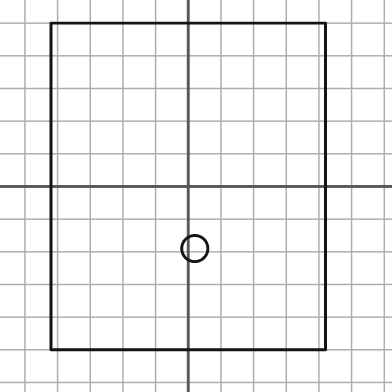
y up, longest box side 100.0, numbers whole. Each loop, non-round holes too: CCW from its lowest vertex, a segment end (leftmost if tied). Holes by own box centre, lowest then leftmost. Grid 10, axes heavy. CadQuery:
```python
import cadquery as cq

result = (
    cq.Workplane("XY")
    .moveTo(-42.0, -50.0)
    .lineTo(42.0, -50.0)
    .lineTo(42.0, 50.0)
    .lineTo(-42.0, 50.0)
    .close()
    .moveTo(2.0, -19.0)
    .circle(4.0)
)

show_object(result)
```